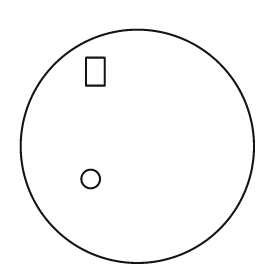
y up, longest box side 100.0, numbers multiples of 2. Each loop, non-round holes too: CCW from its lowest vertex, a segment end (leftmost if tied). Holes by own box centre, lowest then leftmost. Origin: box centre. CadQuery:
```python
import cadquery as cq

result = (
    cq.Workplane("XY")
    .moveTo(0.0, 0.0)
    .circle(50.0)
    .moveTo(-20.0, -14.0)
    .circle(4.0)
    .moveTo(-22.0, 26.0)
    .lineTo(-14.0, 26.0)
    .lineTo(-14.0, 38.0)
    .lineTo(-22.0, 38.0)
    .close()
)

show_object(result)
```